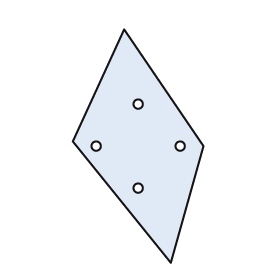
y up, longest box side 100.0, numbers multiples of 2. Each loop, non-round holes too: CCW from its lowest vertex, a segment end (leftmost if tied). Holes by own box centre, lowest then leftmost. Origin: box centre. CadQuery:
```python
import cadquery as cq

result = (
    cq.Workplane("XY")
    .moveTo(14.0, -50.0)
    .lineTo(28.0, 0.0)
    .lineTo(-6.0, 50.0)
    .lineTo(-28.0, 2.0)
    .close()
    .moveTo(0.0, -18.0)
    .circle(2.0)
    .moveTo(-18.0, 0.0)
    .circle(2.0)
    .moveTo(18.0, 0.0)
    .circle(2.0)
    .moveTo(0.0, 18.0)
    .circle(2.0)
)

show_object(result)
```